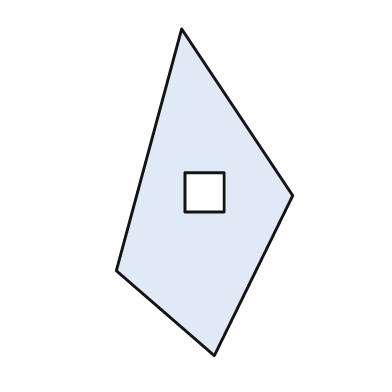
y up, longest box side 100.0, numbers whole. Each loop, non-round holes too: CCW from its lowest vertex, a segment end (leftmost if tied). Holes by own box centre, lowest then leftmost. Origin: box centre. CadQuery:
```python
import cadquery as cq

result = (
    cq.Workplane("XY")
    .moveTo(3.0, -50.0)
    .lineTo(27.0, -1.0)
    .lineTo(-7.0, 50.0)
    .lineTo(-27.0, -24.0)
    .close()
    .moveTo(-6.0, -6.0)
    .lineTo(6.0, -6.0)
    .lineTo(6.0, 6.0)
    .lineTo(-6.0, 6.0)
    .close()
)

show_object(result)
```